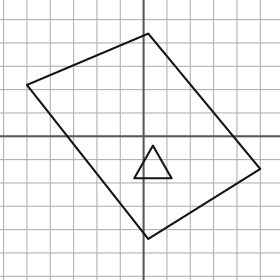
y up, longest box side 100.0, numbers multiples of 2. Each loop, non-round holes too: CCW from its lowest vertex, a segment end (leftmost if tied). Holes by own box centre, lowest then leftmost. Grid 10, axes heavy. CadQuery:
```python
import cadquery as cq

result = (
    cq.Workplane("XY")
    .moveTo(2.0, -44.0)
    .lineTo(50.0, -14.0)
    .lineTo(2.0, 44.0)
    .lineTo(-50.0, 22.0)
    .close()
    .moveTo(-4.0, -18.0)
    .lineTo(12.0, -18.0)
    .lineTo(4.0, -4.0)
    .close()
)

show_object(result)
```